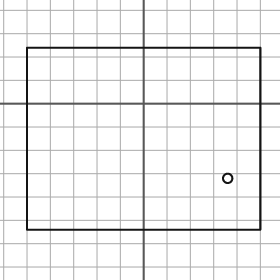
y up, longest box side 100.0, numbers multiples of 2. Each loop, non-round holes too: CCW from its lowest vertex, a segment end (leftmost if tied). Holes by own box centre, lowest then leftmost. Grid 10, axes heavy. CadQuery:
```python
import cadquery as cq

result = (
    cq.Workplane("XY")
    .moveTo(-50.0, -54.0)
    .lineTo(50.0, -54.0)
    .lineTo(50.0, 24.0)
    .lineTo(-50.0, 24.0)
    .close()
    .moveTo(36.0, -32.0)
    .circle(2.0)
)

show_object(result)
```